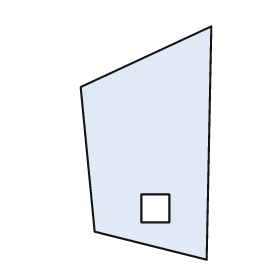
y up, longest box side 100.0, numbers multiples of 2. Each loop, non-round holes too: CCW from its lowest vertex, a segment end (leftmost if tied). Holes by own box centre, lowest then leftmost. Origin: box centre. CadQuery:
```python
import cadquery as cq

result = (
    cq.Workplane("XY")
    .moveTo(26.0, -50.0)
    .lineTo(28.0, 50.0)
    .lineTo(-28.0, 24.0)
    .lineTo(-22.0, -38.0)
    .close()
    .moveTo(-2.0, -34.0)
    .lineTo(10.0, -34.0)
    .lineTo(10.0, -22.0)
    .lineTo(-2.0, -22.0)
    .close()
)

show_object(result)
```